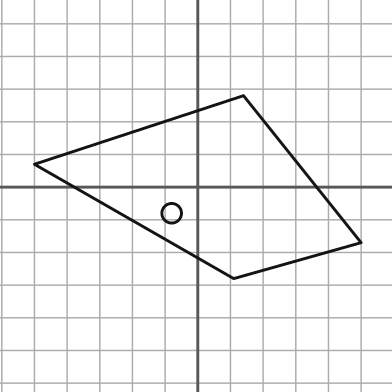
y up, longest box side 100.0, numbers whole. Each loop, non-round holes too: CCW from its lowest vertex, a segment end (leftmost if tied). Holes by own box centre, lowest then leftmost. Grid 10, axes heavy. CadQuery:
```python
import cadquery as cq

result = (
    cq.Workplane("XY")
    .moveTo(11.0, -28.0)
    .lineTo(50.0, -17.0)
    .lineTo(14.0, 28.0)
    .lineTo(-50.0, 7.0)
    .close()
    .moveTo(-8.0, -8.0)
    .circle(3.0)
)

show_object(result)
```